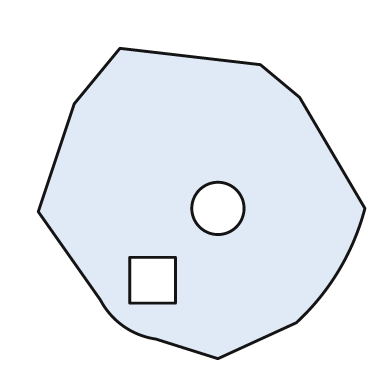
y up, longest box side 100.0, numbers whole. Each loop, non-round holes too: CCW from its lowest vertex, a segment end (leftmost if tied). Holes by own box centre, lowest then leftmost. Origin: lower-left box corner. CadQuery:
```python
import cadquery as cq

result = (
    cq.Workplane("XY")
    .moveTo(55.0, 0.0)
    .lineTo(79.0, 11.0)
    .threePointArc((92.0, 27.0), (100.0, 46.0))
    .lineTo(80.0, 80.0)
    .lineTo(68.0, 90.0)
    .lineTo(25.0, 95.0)
    .lineTo(11.0, 78.0)
    .lineTo(0.0, 45.0)
    .lineTo(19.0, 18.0)
    .threePointArc((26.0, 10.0), (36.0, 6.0))
    .close()
    .moveTo(28.0, 17.0)
    .lineTo(42.0, 17.0)
    .lineTo(42.0, 31.0)
    .lineTo(28.0, 31.0)
    .close()
    .moveTo(55.0, 46.0)
    .circle(8.0)
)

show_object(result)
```